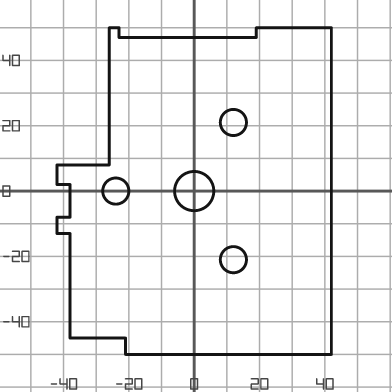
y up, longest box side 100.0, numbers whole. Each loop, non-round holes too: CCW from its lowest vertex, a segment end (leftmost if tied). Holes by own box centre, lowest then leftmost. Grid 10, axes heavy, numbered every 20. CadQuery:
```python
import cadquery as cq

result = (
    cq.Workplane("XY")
    .moveTo(-21.0, -50.0)
    .lineTo(42.0, -50.0)
    .lineTo(42.0, 50.0)
    .lineTo(19.0, 50.0)
    .lineTo(19.0, 47.0)
    .lineTo(-23.0, 47.0)
    .lineTo(-23.0, 50.0)
    .lineTo(-26.0, 50.0)
    .lineTo(-26.0, 8.0)
    .lineTo(-42.0, 8.0)
    .lineTo(-42.0, 2.0)
    .lineTo(-38.0, 2.0)
    .lineTo(-38.0, -8.0)
    .lineTo(-42.0, -8.0)
    .lineTo(-42.0, -13.0)
    .lineTo(-38.0, -13.0)
    .lineTo(-38.0, -45.0)
    .lineTo(-21.0, -45.0)
    .close()
    .moveTo(12.0, -21.0)
    .circle(4.0)
    .moveTo(-24.0, 0.0)
    .circle(4.0)
    .moveTo(0.0, 0.0)
    .circle(6.0)
    .moveTo(12.0, 21.0)
    .circle(4.0)
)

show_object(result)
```